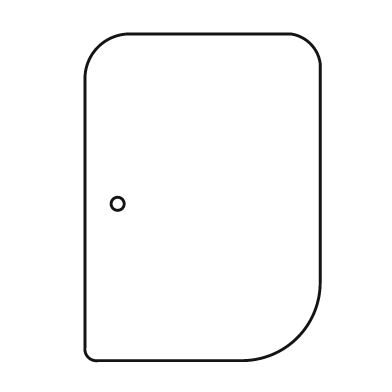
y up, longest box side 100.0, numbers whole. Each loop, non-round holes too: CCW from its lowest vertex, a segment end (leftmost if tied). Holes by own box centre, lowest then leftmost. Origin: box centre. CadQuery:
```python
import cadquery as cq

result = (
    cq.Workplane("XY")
    .moveTo(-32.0, -50.0)
    .lineTo(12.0, -50.0)
    .threePointArc((29.0, -43.0), (36.0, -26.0))
    .lineTo(36.0, 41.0)
    .threePointArc((33.0, 47.0), (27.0, 50.0))
    .lineTo(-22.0, 50.0)
    .threePointArc((-32.0, 46.0), (-36.0, 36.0))
    .lineTo(-36.0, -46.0)
    .threePointArc((-35.0, -49.0), (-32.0, -50.0))
    .close()
    .moveTo(-26.0, -2.0)
    .circle(2.0)
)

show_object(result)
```